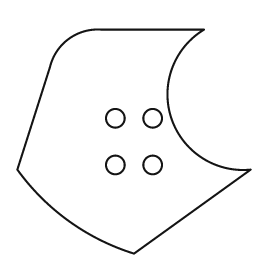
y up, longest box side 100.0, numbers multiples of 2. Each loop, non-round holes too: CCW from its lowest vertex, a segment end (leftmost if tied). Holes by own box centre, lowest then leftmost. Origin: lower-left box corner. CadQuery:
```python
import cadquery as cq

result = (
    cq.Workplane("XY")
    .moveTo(50.0, 0.0)
    .lineTo(100.0, 36.0)
    .threePointArc((66.0, 58.0), (80.0, 96.0))
    .lineTo(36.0, 96.0)
    .threePointArc((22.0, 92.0), (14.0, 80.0))
    .lineTo(0.0, 36.0)
    .threePointArc((22.0, 14.0), (50.0, 0.0))
    .close()
    .moveTo(42.0, 38.0)
    .circle(4.0)
    .moveTo(58.0, 38.0)
    .circle(4.0)
    .moveTo(42.0, 58.0)
    .circle(4.0)
    .moveTo(58.0, 58.0)
    .circle(4.0)
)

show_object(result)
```